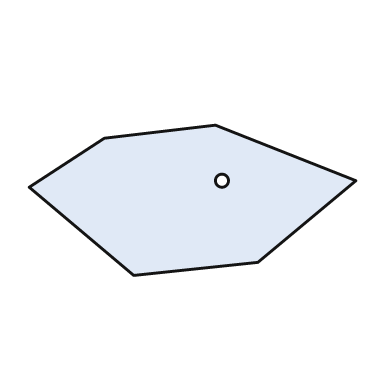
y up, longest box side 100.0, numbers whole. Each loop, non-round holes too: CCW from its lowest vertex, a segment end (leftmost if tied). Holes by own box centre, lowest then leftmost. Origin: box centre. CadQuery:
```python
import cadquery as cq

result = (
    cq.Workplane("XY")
    .moveTo(-18.0, -23.0)
    .lineTo(20.0, -19.0)
    .lineTo(50.0, 6.0)
    .lineTo(7.0, 23.0)
    .lineTo(-27.0, 19.0)
    .lineTo(-50.0, 4.0)
    .close()
    .moveTo(9.0, 6.0)
    .circle(2.0)
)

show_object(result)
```